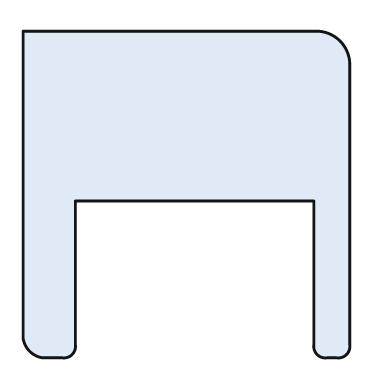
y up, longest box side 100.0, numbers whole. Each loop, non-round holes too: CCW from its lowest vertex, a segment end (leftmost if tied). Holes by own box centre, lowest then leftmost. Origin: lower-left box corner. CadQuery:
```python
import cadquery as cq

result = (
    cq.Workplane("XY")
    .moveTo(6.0, 0.0)
    .lineTo(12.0, 0.0)
    .threePointArc((15.0, 1.0), (16.0, 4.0))
    .lineTo(16.0, 48.0)
    .lineTo(89.0, 48.0)
    .lineTo(89.0, 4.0)
    .threePointArc((90.0, 1.0), (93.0, 0.0))
    .lineTo(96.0, 0.0)
    .threePointArc((99.0, 1.0), (100.0, 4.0))
    .lineTo(100.0, 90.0)
    .threePointArc((97.0, 97.0), (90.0, 100.0))
    .lineTo(0.0, 100.0)
    .lineTo(0.0, 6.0)
    .threePointArc((2.0, 2.0), (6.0, 0.0))
    .close()
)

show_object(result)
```